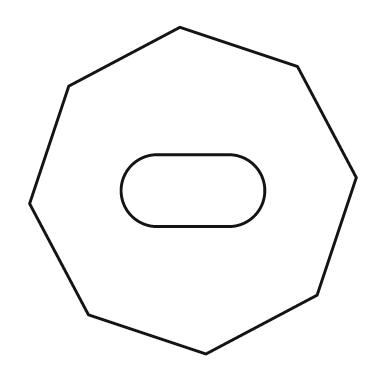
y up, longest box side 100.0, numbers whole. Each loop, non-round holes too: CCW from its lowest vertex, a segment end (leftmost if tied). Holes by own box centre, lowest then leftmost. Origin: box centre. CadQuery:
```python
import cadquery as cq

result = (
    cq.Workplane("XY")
    .moveTo(4.0, -50.0)
    .lineTo(38.0, -32.0)
    .lineTo(50.0, 4.0)
    .lineTo(32.0, 38.0)
    .lineTo(-4.0, 50.0)
    .lineTo(-38.0, 32.0)
    .lineTo(-50.0, -4.0)
    .lineTo(-32.0, -38.0)
    .close()
    .moveTo(-11.0, -11.0)
    .lineTo(11.0, -11.0)
    .threePointArc((22.0, 0.0), (11.0, 11.0))
    .lineTo(-11.0, 11.0)
    .threePointArc((-22.0, 0.0), (-11.0, -11.0))
    .close()
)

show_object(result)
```